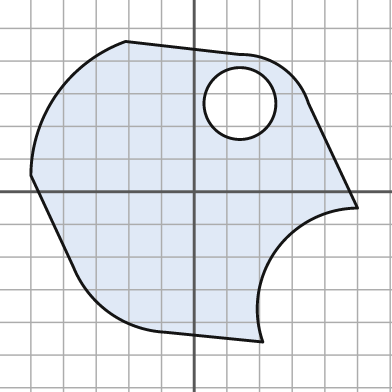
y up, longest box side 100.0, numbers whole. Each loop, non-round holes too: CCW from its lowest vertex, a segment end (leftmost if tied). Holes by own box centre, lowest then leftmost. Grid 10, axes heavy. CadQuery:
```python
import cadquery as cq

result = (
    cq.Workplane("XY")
    .moveTo(21.0, -46.0)
    .threePointArc((25.0, -18.0), (50.0, -5.0))
    .lineTo(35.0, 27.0)
    .threePointArc((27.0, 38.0), (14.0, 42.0))
    .lineTo(-21.0, 46.0)
    .threePointArc((-42.0, 30.0), (-50.0, 5.0))
    .lineTo(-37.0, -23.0)
    .threePointArc((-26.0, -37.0), (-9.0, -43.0))
    .close()
    .moveTo(14.0, 27.0)
    .circle(11.0)
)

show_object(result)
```